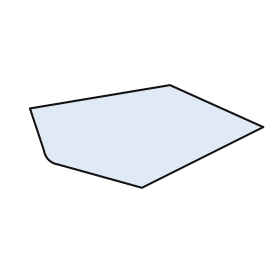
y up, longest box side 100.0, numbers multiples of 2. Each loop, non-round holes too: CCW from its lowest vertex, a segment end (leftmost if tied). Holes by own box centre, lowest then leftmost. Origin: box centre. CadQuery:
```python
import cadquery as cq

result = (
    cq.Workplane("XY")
    .moveTo(-2.0, -22.0)
    .lineTo(50.0, 4.0)
    .lineTo(10.0, 22.0)
    .lineTo(-50.0, 12.0)
    .lineTo(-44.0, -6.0)
    .threePointArc((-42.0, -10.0), (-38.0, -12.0))
    .close()
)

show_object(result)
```